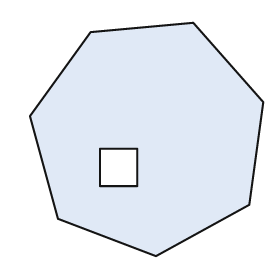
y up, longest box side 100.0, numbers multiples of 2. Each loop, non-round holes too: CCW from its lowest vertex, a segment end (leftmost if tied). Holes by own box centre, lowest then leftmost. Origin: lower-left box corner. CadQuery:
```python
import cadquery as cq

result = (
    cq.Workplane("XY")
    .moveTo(54.0, 0.0)
    .lineTo(94.0, 22.0)
    .lineTo(100.0, 66.0)
    .lineTo(70.0, 100.0)
    .lineTo(26.0, 96.0)
    .lineTo(0.0, 60.0)
    .lineTo(12.0, 16.0)
    .close()
    .moveTo(30.0, 30.0)
    .lineTo(46.0, 30.0)
    .lineTo(46.0, 46.0)
    .lineTo(30.0, 46.0)
    .close()
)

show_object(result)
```